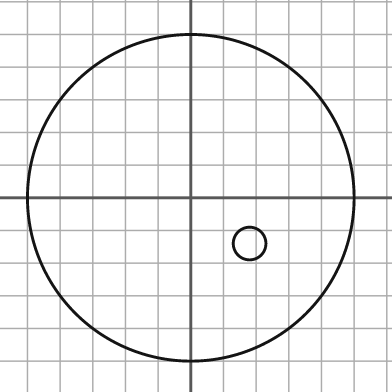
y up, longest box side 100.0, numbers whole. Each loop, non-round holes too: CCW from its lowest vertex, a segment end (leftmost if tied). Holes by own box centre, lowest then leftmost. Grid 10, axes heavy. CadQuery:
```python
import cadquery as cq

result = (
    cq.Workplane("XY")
    .moveTo(0.0, 0.0)
    .circle(50.0)
    .moveTo(18.0, -14.0)
    .circle(5.0)
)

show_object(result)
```